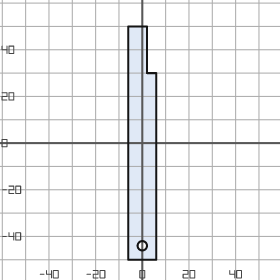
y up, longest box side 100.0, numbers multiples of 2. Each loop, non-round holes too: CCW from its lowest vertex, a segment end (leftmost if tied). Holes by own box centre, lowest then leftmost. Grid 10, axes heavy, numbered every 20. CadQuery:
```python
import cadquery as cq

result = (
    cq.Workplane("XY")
    .moveTo(-6.0, -50.0)
    .lineTo(6.0, -50.0)
    .lineTo(6.0, 30.0)
    .lineTo(2.0, 30.0)
    .lineTo(2.0, 50.0)
    .lineTo(-6.0, 50.0)
    .close()
    .moveTo(0.0, -44.0)
    .circle(2.0)
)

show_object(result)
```